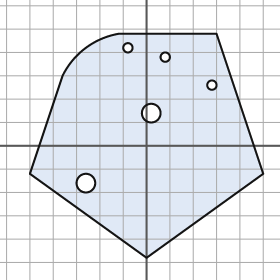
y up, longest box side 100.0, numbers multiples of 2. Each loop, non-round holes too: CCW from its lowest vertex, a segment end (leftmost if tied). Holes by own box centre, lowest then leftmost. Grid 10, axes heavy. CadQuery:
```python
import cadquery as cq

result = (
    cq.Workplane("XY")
    .moveTo(0.0, -48.0)
    .lineTo(50.0, -12.0)
    .lineTo(30.0, 48.0)
    .lineTo(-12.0, 48.0)
    .threePointArc((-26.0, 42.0), (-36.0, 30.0))
    .lineTo(-50.0, -12.0)
    .close()
    .moveTo(-26.0, -16.0)
    .circle(4.0)
    .moveTo(2.0, 14.0)
    .circle(4.0)
    .moveTo(28.0, 26.0)
    .circle(2.0)
    .moveTo(8.0, 38.0)
    .circle(2.0)
    .moveTo(-8.0, 42.0)
    .circle(2.0)
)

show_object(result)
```